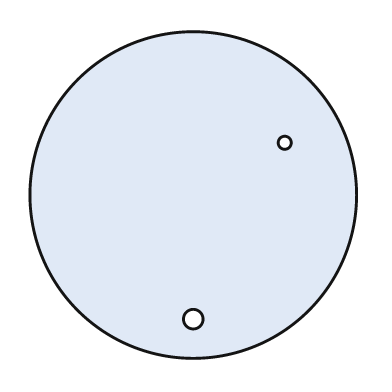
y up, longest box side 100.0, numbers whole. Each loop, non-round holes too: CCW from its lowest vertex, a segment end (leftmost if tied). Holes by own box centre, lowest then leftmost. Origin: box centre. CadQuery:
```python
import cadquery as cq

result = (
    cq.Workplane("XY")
    .moveTo(0.0, 0.0)
    .circle(50.0)
    .moveTo(0.0, -38.0)
    .circle(3.0)
    .moveTo(28.0, 16.0)
    .circle(2.0)
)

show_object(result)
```